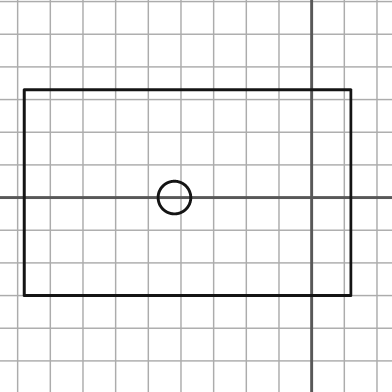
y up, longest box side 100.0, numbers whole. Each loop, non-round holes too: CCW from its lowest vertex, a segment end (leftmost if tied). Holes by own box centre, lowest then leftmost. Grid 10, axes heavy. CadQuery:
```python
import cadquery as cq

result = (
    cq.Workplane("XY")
    .moveTo(-88.0, -30.0)
    .lineTo(12.0, -30.0)
    .lineTo(12.0, 33.0)
    .lineTo(-88.0, 33.0)
    .close()
    .moveTo(-42.0, 0.0)
    .circle(5.0)
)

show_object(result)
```